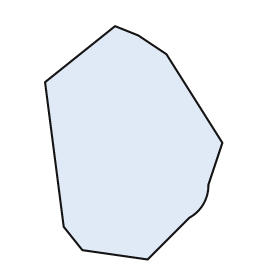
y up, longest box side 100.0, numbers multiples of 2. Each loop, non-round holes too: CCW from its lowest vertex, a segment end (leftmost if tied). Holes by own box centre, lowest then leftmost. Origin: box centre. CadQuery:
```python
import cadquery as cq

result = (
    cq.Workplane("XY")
    .moveTo(6.0, -50.0)
    .lineTo(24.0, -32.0)
    .threePointArc((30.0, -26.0), (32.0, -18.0))
    .lineTo(38.0, 0.0)
    .lineTo(14.0, 38.0)
    .lineTo(2.0, 46.0)
    .lineTo(-8.0, 50.0)
    .lineTo(-38.0, 26.0)
    .lineTo(-30.0, -36.0)
    .lineTo(-22.0, -46.0)
    .close()
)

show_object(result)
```